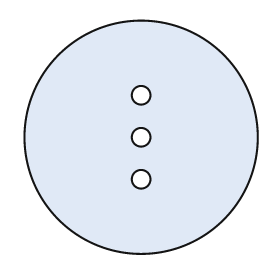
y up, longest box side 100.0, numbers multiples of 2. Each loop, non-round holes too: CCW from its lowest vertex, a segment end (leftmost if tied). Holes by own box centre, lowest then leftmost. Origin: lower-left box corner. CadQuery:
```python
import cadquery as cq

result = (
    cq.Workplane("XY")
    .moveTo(50.0, 50.0)
    .circle(50.0)
    .moveTo(50.0, 32.0)
    .circle(4.0)
    .moveTo(50.0, 50.0)
    .circle(4.0)
    .moveTo(50.0, 68.0)
    .circle(4.0)
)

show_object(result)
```